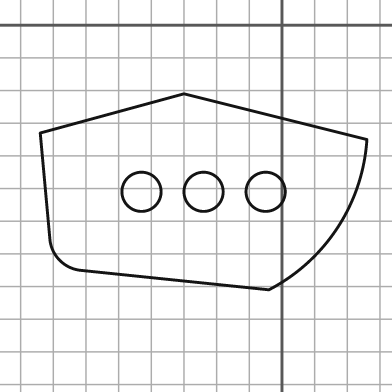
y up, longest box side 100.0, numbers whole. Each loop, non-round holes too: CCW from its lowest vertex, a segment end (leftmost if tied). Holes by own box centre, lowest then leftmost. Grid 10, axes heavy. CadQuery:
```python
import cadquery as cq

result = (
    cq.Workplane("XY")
    .moveTo(-4.0, -81.0)
    .threePointArc((17.0, -62.0), (26.0, -35.0))
    .lineTo(-30.0, -21.0)
    .lineTo(-74.0, -33.0)
    .lineTo(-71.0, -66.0)
    .threePointArc((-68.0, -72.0), (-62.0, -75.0))
    .close()
    .moveTo(-43.0, -51.0)
    .circle(6.0)
    .moveTo(-24.0, -51.0)
    .circle(6.0)
    .moveTo(-5.0, -51.0)
    .circle(6.0)
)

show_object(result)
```